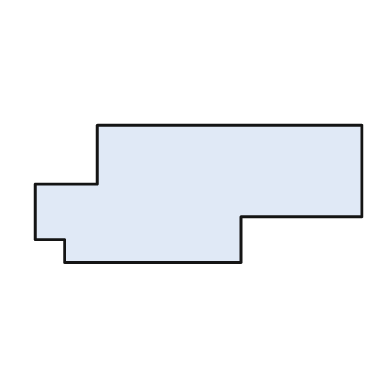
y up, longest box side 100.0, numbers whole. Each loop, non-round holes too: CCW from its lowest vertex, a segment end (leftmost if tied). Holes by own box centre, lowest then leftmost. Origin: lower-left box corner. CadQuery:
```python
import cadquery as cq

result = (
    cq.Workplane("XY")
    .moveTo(9.0, 0.0)
    .lineTo(63.0, 0.0)
    .lineTo(63.0, 14.0)
    .lineTo(100.0, 14.0)
    .lineTo(100.0, 42.0)
    .lineTo(19.0, 42.0)
    .lineTo(19.0, 24.0)
    .lineTo(0.0, 24.0)
    .lineTo(0.0, 7.0)
    .lineTo(9.0, 7.0)
    .close()
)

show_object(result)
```